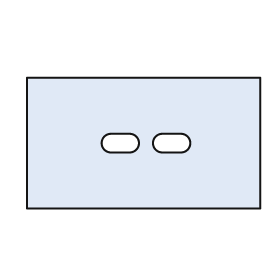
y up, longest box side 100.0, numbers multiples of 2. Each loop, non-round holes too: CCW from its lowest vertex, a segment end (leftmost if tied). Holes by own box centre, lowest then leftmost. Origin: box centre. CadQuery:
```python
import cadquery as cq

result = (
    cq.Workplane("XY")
    .moveTo(-50.0, -28.0)
    .lineTo(50.0, -28.0)
    .lineTo(50.0, 28.0)
    .lineTo(-50.0, 28.0)
    .close()
    .moveTo(-14.0, -4.0)
    .lineTo(-6.0, -4.0)
    .threePointArc((-2.0, 0.0), (-6.0, 4.0))
    .lineTo(-14.0, 4.0)
    .threePointArc((-18.0, 0.0), (-14.0, -4.0))
    .close()
    .moveTo(8.0, -4.0)
    .lineTo(16.0, -4.0)
    .threePointArc((20.0, 0.0), (16.0, 4.0))
    .lineTo(8.0, 4.0)
    .threePointArc((4.0, 0.0), (8.0, -4.0))
    .close()
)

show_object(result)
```